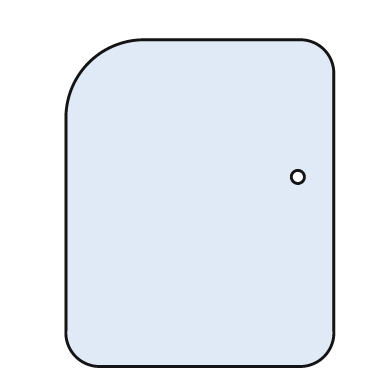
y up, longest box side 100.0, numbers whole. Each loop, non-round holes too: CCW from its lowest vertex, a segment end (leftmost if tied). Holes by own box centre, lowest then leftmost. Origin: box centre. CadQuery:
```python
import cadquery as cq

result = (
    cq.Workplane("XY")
    .moveTo(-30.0, -50.0)
    .lineTo(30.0, -50.0)
    .threePointArc((38.0, -47.0), (41.0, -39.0))
    .lineTo(41.0, 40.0)
    .threePointArc((38.0, 47.0), (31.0, 50.0))
    .lineTo(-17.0, 50.0)
    .threePointArc((-34.0, 43.0), (-41.0, 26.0))
    .lineTo(-41.0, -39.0)
    .threePointArc((-38.0, -47.0), (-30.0, -50.0))
    .close()
    .moveTo(30.0, 8.0)
    .circle(2.0)
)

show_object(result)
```